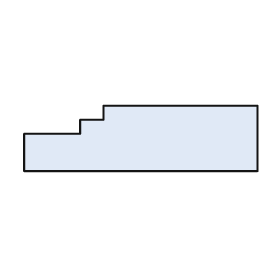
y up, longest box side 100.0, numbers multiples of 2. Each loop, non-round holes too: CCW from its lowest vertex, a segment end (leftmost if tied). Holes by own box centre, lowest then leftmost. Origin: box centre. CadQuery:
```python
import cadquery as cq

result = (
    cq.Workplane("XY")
    .moveTo(-50.0, -14.0)
    .lineTo(50.0, -14.0)
    .lineTo(50.0, 14.0)
    .lineTo(-16.0, 14.0)
    .lineTo(-16.0, 8.0)
    .lineTo(-26.0, 8.0)
    .lineTo(-26.0, 2.0)
    .lineTo(-50.0, 2.0)
    .close()
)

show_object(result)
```